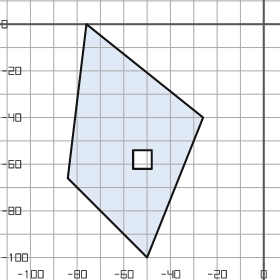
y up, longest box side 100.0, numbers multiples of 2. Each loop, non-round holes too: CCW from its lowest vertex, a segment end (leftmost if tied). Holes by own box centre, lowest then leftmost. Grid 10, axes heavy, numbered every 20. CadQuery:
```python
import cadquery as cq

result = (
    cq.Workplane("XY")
    .moveTo(-50.0, -100.0)
    .lineTo(-26.0, -40.0)
    .lineTo(-76.0, 0.0)
    .lineTo(-84.0, -66.0)
    .close()
    .moveTo(-56.0, -62.0)
    .lineTo(-48.0, -62.0)
    .lineTo(-48.0, -54.0)
    .lineTo(-56.0, -54.0)
    .close()
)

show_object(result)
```